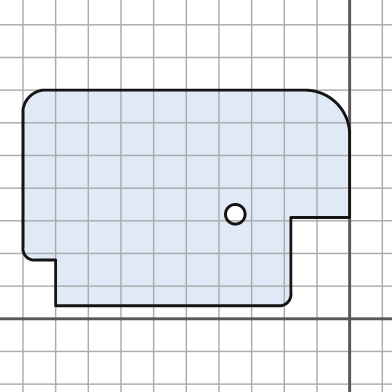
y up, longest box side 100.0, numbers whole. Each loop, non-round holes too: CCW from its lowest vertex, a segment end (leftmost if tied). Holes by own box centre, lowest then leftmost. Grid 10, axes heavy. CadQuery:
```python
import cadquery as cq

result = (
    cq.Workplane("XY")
    .moveTo(-90.0, 4.0)
    .lineTo(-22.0, 4.0)
    .threePointArc((-19.0, 5.0), (-18.0, 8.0))
    .lineTo(-18.0, 31.0)
    .lineTo(0.0, 31.0)
    .lineTo(0.0, 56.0)
    .threePointArc((-4.0, 66.0), (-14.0, 70.0))
    .lineTo(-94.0, 70.0)
    .threePointArc((-98.0, 68.0), (-100.0, 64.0))
    .lineTo(-100.0, 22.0)
    .threePointArc((-99.0, 19.0), (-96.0, 18.0))
    .lineTo(-90.0, 18.0)
    .close()
    .moveTo(-35.0, 32.0)
    .circle(3.0)
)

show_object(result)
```